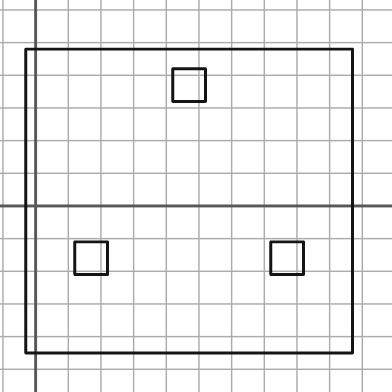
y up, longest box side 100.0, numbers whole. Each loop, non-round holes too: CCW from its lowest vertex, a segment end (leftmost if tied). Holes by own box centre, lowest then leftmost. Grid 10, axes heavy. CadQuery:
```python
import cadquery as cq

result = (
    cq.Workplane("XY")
    .moveTo(-3.0, -45.0)
    .lineTo(97.0, -45.0)
    .lineTo(97.0, 48.0)
    .lineTo(-3.0, 48.0)
    .close()
    .moveTo(12.0, -21.0)
    .lineTo(22.0, -21.0)
    .lineTo(22.0, -11.0)
    .lineTo(12.0, -11.0)
    .close()
    .moveTo(72.0, -21.0)
    .lineTo(82.0, -21.0)
    .lineTo(82.0, -11.0)
    .lineTo(72.0, -11.0)
    .close()
    .moveTo(42.0, 32.0)
    .lineTo(52.0, 32.0)
    .lineTo(52.0, 42.0)
    .lineTo(42.0, 42.0)
    .close()
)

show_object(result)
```